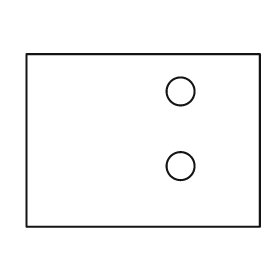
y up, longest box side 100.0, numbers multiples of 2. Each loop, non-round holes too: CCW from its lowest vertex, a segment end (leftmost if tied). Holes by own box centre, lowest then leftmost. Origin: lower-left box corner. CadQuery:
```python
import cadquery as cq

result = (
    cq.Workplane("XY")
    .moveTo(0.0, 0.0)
    .lineTo(100.0, 0.0)
    .lineTo(100.0, 74.0)
    .lineTo(0.0, 74.0)
    .close()
    .moveTo(66.0, 26.0)
    .circle(6.0)
    .moveTo(66.0, 58.0)
    .circle(6.0)
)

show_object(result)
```